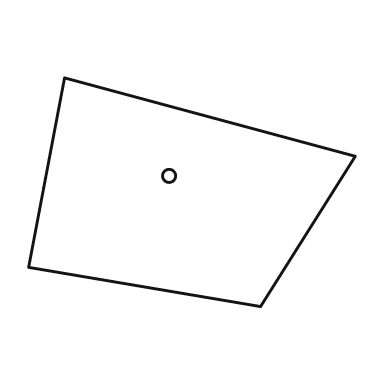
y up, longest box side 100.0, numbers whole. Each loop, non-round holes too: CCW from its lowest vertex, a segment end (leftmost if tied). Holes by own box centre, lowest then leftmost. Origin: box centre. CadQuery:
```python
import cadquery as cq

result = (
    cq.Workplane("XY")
    .moveTo(21.0, -35.0)
    .lineTo(50.0, 11.0)
    .lineTo(-39.0, 35.0)
    .lineTo(-50.0, -23.0)
    .close()
    .moveTo(-7.0, 5.0)
    .circle(2.0)
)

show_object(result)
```